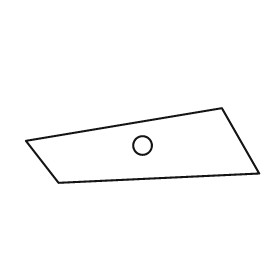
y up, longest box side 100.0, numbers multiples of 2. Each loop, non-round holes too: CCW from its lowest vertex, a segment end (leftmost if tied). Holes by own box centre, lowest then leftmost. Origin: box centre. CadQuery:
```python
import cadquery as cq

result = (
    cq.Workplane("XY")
    .moveTo(-36.0, -16.0)
    .lineTo(50.0, -12.0)
    .lineTo(34.0, 16.0)
    .lineTo(-50.0, 2.0)
    .close()
    .moveTo(0.0, 0.0)
    .circle(4.0)
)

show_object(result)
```